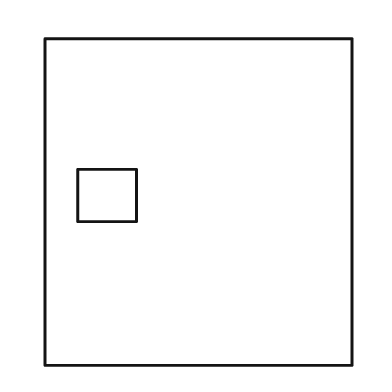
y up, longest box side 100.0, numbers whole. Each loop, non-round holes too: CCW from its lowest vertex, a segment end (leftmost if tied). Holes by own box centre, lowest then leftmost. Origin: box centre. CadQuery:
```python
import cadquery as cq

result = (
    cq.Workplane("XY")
    .moveTo(-47.0, -50.0)
    .lineTo(47.0, -50.0)
    .lineTo(47.0, 50.0)
    .lineTo(-47.0, 50.0)
    .close()
    .moveTo(-37.0, -6.0)
    .lineTo(-19.0, -6.0)
    .lineTo(-19.0, 10.0)
    .lineTo(-37.0, 10.0)
    .close()
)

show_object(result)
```